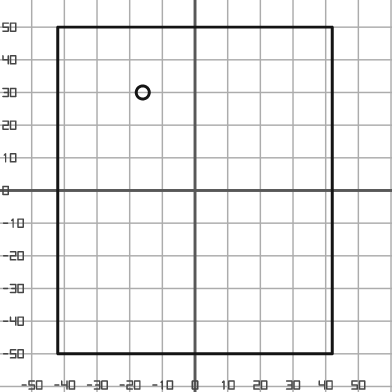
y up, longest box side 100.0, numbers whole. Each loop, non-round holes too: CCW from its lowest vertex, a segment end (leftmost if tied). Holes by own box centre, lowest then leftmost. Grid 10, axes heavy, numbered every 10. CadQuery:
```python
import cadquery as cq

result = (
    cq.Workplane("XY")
    .moveTo(-42.0, -50.0)
    .lineTo(42.0, -50.0)
    .lineTo(42.0, 50.0)
    .lineTo(-42.0, 50.0)
    .close()
    .moveTo(-16.0, 30.0)
    .circle(2.0)
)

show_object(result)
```